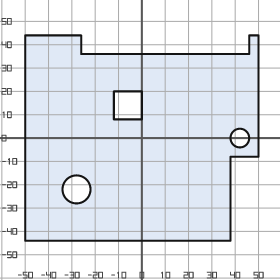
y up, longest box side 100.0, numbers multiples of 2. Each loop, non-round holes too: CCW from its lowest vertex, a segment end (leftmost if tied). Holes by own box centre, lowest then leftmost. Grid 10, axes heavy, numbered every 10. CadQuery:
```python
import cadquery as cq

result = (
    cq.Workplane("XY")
    .moveTo(-50.0, -44.0)
    .lineTo(38.0, -44.0)
    .lineTo(38.0, -8.0)
    .lineTo(50.0, -8.0)
    .lineTo(50.0, 44.0)
    .lineTo(46.0, 44.0)
    .lineTo(46.0, 36.0)
    .lineTo(-26.0, 36.0)
    .lineTo(-26.0, 44.0)
    .lineTo(-50.0, 44.0)
    .close()
    .moveTo(-28.0, -22.0)
    .circle(6.0)
    .moveTo(42.0, 0.0)
    .circle(4.0)
    .moveTo(-12.0, 8.0)
    .lineTo(0.0, 8.0)
    .lineTo(0.0, 20.0)
    .lineTo(-12.0, 20.0)
    .close()
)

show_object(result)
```